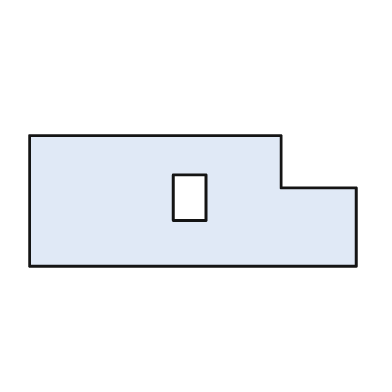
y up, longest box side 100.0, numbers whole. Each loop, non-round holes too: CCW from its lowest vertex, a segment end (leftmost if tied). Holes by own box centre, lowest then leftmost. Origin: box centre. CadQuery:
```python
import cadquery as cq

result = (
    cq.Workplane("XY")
    .moveTo(-50.0, -20.0)
    .lineTo(50.0, -20.0)
    .lineTo(50.0, 4.0)
    .lineTo(27.0, 4.0)
    .lineTo(27.0, 20.0)
    .lineTo(-50.0, 20.0)
    .close()
    .moveTo(-6.0, -6.0)
    .lineTo(4.0, -6.0)
    .lineTo(4.0, 8.0)
    .lineTo(-6.0, 8.0)
    .close()
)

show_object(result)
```